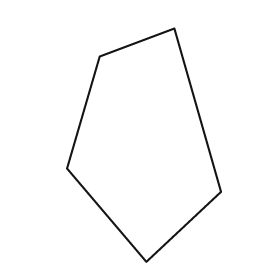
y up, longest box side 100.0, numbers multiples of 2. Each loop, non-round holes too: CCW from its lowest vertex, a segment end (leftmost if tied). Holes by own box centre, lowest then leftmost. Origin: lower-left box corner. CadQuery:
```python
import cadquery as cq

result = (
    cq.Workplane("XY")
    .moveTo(34.0, 0.0)
    .lineTo(66.0, 30.0)
    .lineTo(46.0, 100.0)
    .lineTo(14.0, 88.0)
    .lineTo(0.0, 40.0)
    .close()
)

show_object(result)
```